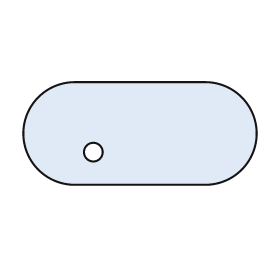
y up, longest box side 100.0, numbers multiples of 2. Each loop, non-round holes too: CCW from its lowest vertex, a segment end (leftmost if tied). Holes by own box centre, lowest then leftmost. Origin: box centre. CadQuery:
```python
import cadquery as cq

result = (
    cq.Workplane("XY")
    .moveTo(-28.0, -22.0)
    .lineTo(28.0, -22.0)
    .threePointArc((50.0, 0.0), (28.0, 22.0))
    .lineTo(-28.0, 22.0)
    .threePointArc((-50.0, 0.0), (-28.0, -22.0))
    .close()
    .moveTo(-20.0, -8.0)
    .circle(4.0)
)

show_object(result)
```